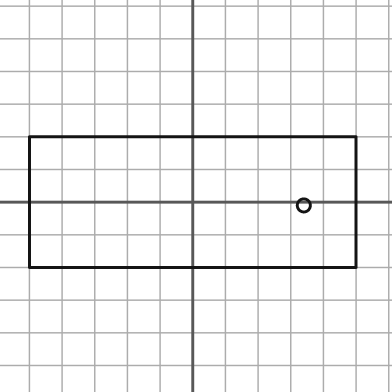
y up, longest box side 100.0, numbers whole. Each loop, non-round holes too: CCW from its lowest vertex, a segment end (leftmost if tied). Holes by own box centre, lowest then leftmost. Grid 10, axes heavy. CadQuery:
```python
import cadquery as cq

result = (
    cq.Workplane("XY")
    .moveTo(-50.0, -20.0)
    .lineTo(50.0, -20.0)
    .lineTo(50.0, 20.0)
    .lineTo(-50.0, 20.0)
    .close()
    .moveTo(34.0, -1.0)
    .circle(2.0)
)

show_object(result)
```